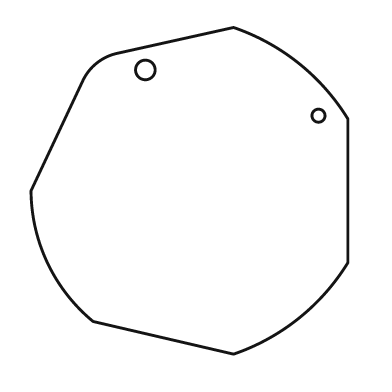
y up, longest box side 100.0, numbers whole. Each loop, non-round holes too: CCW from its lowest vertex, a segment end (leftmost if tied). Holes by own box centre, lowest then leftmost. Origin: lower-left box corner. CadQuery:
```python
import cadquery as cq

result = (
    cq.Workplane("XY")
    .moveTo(62.0, 0.0)
    .threePointArc((82.0, 11.0), (97.0, 28.0))
    .lineTo(97.0, 72.0)
    .threePointArc((82.0, 89.0), (62.0, 100.0))
    .lineTo(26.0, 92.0)
    .threePointArc((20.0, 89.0), (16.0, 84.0))
    .lineTo(0.0, 50.0)
    .threePointArc((5.0, 28.0), (19.0, 10.0))
    .close()
    .moveTo(88.0, 73.0)
    .circle(2.0)
    .moveTo(35.0, 87.0)
    .circle(3.0)
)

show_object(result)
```